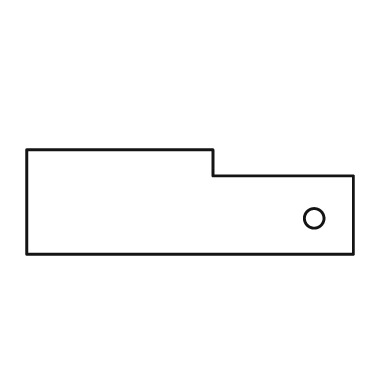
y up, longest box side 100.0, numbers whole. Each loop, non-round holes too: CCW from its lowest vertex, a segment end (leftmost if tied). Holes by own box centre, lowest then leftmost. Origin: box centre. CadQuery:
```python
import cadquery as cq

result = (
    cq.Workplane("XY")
    .moveTo(-50.0, -16.0)
    .lineTo(50.0, -16.0)
    .lineTo(50.0, 8.0)
    .lineTo(7.0, 8.0)
    .lineTo(7.0, 16.0)
    .lineTo(-50.0, 16.0)
    .close()
    .moveTo(38.0, -5.0)
    .circle(3.0)
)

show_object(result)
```